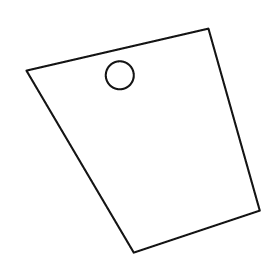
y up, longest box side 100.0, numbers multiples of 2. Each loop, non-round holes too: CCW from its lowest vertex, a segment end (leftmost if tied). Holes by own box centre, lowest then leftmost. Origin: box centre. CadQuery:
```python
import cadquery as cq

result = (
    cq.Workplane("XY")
    .moveTo(-4.0, -48.0)
    .lineTo(50.0, -30.0)
    .lineTo(28.0, 48.0)
    .lineTo(-50.0, 30.0)
    .close()
    .moveTo(-10.0, 28.0)
    .circle(6.0)
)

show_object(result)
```